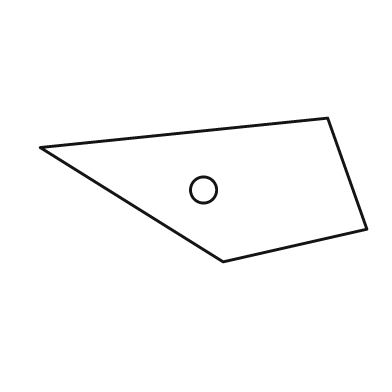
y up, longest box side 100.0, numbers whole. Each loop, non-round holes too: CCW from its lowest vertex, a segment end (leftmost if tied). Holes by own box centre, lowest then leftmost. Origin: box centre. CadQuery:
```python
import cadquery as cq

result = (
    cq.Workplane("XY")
    .moveTo(6.0, -22.0)
    .lineTo(50.0, -12.0)
    .lineTo(38.0, 22.0)
    .lineTo(-50.0, 13.0)
    .close()
    .moveTo(0.0, 0.0)
    .circle(4.0)
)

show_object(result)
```